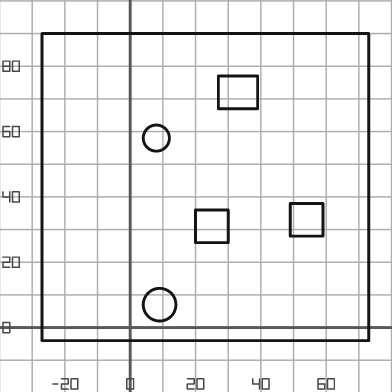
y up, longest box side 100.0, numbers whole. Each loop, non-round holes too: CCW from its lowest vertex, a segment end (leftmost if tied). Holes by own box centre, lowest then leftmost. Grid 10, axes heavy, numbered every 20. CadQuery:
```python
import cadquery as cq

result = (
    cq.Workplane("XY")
    .moveTo(-27.0, -4.0)
    .lineTo(73.0, -4.0)
    .lineTo(73.0, 90.0)
    .lineTo(-27.0, 90.0)
    .close()
    .moveTo(9.0, 7.0)
    .circle(5.0)
    .moveTo(20.0, 26.0)
    .lineTo(30.0, 26.0)
    .lineTo(30.0, 36.0)
    .lineTo(20.0, 36.0)
    .close()
    .moveTo(49.0, 28.0)
    .lineTo(59.0, 28.0)
    .lineTo(59.0, 38.0)
    .lineTo(49.0, 38.0)
    .close()
    .moveTo(8.0, 58.0)
    .circle(4.0)
    .moveTo(27.0, 67.0)
    .lineTo(39.0, 67.0)
    .lineTo(39.0, 77.0)
    .lineTo(27.0, 77.0)
    .close()
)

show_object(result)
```